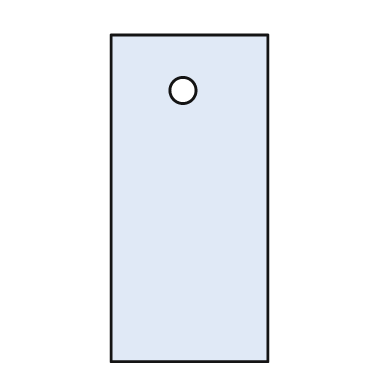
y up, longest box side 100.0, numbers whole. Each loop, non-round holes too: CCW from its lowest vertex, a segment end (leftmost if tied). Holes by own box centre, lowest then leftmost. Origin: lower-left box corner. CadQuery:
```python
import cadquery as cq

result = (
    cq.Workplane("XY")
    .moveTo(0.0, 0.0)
    .lineTo(48.0, 0.0)
    .lineTo(48.0, 100.0)
    .lineTo(0.0, 100.0)
    .close()
    .moveTo(22.0, 83.0)
    .circle(4.0)
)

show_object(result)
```